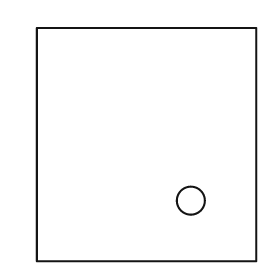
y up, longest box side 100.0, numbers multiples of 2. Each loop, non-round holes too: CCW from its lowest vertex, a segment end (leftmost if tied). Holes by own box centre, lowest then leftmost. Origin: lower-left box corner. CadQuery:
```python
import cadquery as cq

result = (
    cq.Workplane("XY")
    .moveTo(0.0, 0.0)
    .lineTo(94.0, 0.0)
    .lineTo(94.0, 100.0)
    .lineTo(0.0, 100.0)
    .close()
    .moveTo(66.0, 26.0)
    .circle(6.0)
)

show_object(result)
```